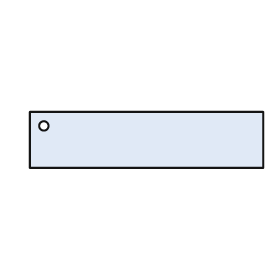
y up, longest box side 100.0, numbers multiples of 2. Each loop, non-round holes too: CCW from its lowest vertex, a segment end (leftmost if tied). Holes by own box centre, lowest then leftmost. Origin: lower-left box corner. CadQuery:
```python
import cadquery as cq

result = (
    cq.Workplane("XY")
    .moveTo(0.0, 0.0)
    .lineTo(100.0, 0.0)
    .lineTo(100.0, 24.0)
    .lineTo(0.0, 24.0)
    .close()
    .moveTo(6.0, 18.0)
    .circle(2.0)
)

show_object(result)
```